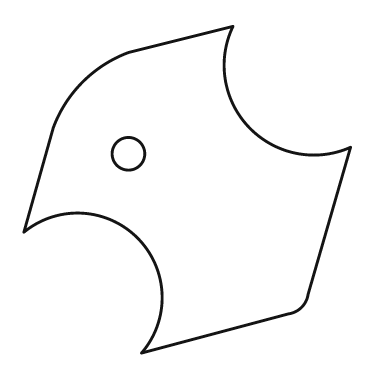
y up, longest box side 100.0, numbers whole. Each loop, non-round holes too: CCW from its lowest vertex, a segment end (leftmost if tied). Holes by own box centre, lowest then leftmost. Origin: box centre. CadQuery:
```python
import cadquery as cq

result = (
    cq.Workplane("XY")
    .moveTo(-14.0, -50.0)
    .lineTo(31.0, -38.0)
    .threePointArc((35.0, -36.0), (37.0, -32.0))
    .lineTo(50.0, 13.0)
    .threePointArc((19.0, 19.0), (14.0, 50.0))
    .lineTo(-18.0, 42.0)
    .threePointArc((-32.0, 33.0), (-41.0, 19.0))
    .lineTo(-50.0, -13.0)
    .threePointArc((-15.0, -15.0), (-14.0, -50.0))
    .close()
    .moveTo(-18.0, 11.0)
    .circle(5.0)
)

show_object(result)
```